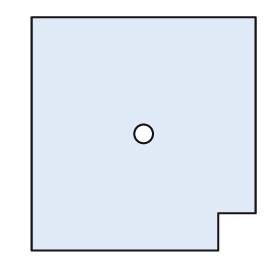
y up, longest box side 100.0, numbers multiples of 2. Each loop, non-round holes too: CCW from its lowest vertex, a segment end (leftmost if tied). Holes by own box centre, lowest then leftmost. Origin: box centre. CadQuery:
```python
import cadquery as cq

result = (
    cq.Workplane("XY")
    .moveTo(-48.0, -50.0)
    .lineTo(32.0, -50.0)
    .lineTo(32.0, -34.0)
    .lineTo(48.0, -34.0)
    .lineTo(48.0, 50.0)
    .lineTo(-48.0, 50.0)
    .close()
    .moveTo(0.0, 0.0)
    .circle(4.0)
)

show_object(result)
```